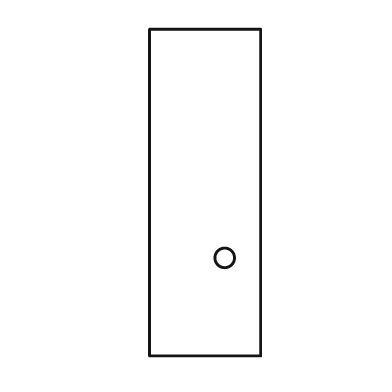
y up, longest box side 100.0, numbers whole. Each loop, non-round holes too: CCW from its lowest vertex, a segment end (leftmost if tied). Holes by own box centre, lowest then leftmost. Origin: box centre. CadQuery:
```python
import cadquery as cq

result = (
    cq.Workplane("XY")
    .moveTo(-17.0, -50.0)
    .lineTo(17.0, -50.0)
    .lineTo(17.0, 50.0)
    .lineTo(-17.0, 50.0)
    .close()
    .moveTo(6.0, -20.0)
    .circle(3.0)
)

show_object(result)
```